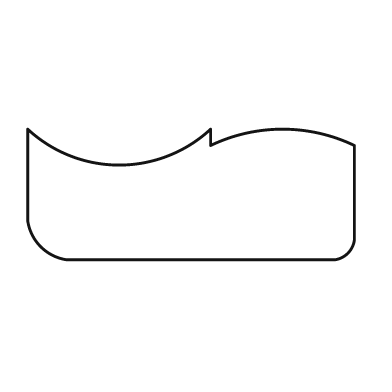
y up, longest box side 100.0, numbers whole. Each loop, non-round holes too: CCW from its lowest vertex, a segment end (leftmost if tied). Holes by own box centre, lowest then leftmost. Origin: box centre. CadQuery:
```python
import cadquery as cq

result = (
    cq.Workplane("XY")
    .moveTo(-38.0, -20.0)
    .lineTo(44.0, -20.0)
    .threePointArc((48.0, -18.0), (50.0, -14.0))
    .lineTo(50.0, 15.0)
    .threePointArc((28.0, 20.0), (6.0, 15.0))
    .lineTo(6.0, 20.0)
    .threePointArc((-22.0, 9.0), (-50.0, 20.0))
    .lineTo(-50.0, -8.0)
    .threePointArc((-46.0, -16.0), (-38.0, -20.0))
    .close()
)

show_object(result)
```